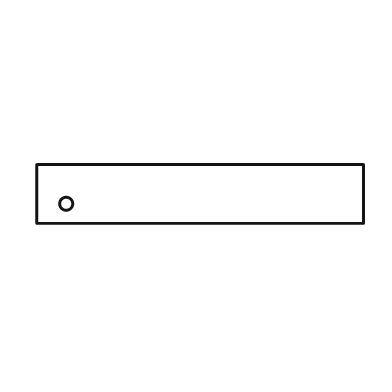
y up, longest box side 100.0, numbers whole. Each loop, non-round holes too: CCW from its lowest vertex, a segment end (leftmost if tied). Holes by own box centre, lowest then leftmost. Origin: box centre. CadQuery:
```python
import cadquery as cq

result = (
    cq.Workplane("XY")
    .moveTo(-50.0, -9.0)
    .lineTo(50.0, -9.0)
    .lineTo(50.0, 9.0)
    .lineTo(-50.0, 9.0)
    .close()
    .moveTo(-41.0, -3.0)
    .circle(2.0)
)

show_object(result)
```